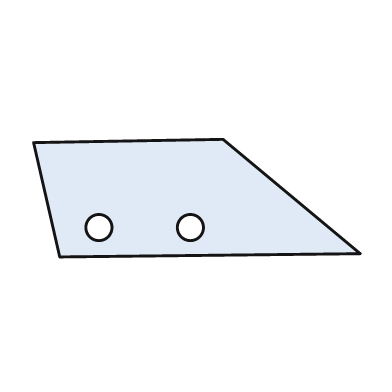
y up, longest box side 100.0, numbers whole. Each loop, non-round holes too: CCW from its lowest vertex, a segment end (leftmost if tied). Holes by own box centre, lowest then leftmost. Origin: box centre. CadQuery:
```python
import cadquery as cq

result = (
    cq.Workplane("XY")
    .moveTo(-42.0, -18.0)
    .lineTo(50.0, -17.0)
    .lineTo(8.0, 18.0)
    .lineTo(-50.0, 17.0)
    .close()
    .moveTo(-30.0, -9.0)
    .circle(4.0)
    .moveTo(-2.0, -9.0)
    .circle(4.0)
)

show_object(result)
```